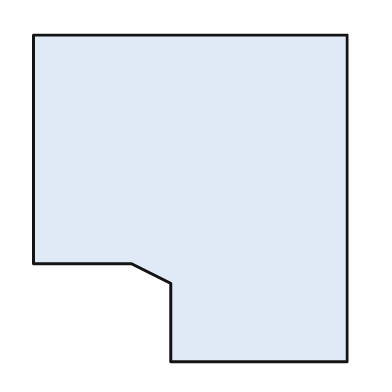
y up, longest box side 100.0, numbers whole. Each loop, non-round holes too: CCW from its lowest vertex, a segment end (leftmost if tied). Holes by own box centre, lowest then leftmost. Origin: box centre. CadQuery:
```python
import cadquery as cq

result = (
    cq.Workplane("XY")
    .moveTo(-6.0, -50.0)
    .lineTo(48.0, -50.0)
    .lineTo(48.0, 50.0)
    .lineTo(-48.0, 50.0)
    .lineTo(-48.0, -20.0)
    .lineTo(-18.0, -20.0)
    .lineTo(-6.0, -26.0)
    .close()
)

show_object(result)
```